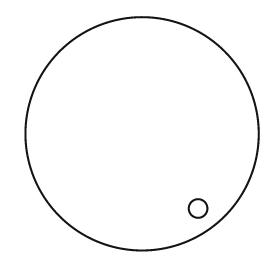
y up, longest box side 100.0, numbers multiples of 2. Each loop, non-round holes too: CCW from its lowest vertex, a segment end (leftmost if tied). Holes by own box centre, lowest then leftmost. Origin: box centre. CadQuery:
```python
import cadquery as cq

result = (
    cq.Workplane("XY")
    .moveTo(0.0, 0.0)
    .circle(50.0)
    .moveTo(24.0, -32.0)
    .circle(4.0)
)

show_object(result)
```